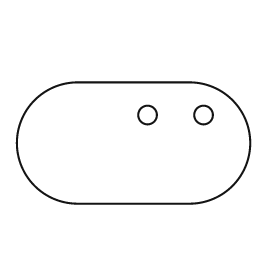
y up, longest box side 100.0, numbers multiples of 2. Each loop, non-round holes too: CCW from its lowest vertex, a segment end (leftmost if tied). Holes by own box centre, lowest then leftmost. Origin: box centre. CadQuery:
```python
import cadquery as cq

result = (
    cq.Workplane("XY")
    .moveTo(-24.0, -26.0)
    .lineTo(24.0, -26.0)
    .threePointArc((50.0, 0.0), (24.0, 26.0))
    .lineTo(-24.0, 26.0)
    .threePointArc((-50.0, 0.0), (-24.0, -26.0))
    .close()
    .moveTo(6.0, 12.0)
    .circle(4.0)
    .moveTo(30.0, 12.0)
    .circle(4.0)
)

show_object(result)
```